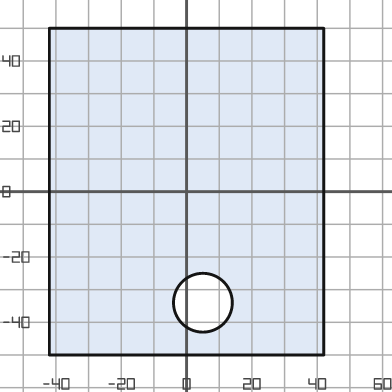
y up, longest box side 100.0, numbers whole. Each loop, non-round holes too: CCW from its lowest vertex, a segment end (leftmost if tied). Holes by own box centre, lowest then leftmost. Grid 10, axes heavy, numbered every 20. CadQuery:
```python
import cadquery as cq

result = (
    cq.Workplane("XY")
    .moveTo(-42.0, -50.0)
    .lineTo(42.0, -50.0)
    .lineTo(42.0, 50.0)
    .lineTo(-42.0, 50.0)
    .close()
    .moveTo(5.0, -34.0)
    .circle(9.0)
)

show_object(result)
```